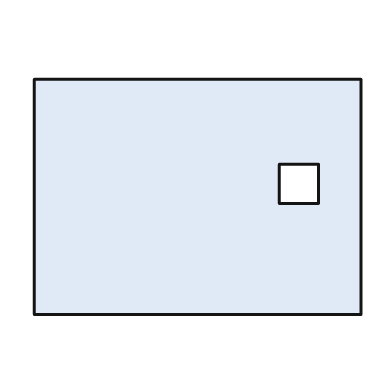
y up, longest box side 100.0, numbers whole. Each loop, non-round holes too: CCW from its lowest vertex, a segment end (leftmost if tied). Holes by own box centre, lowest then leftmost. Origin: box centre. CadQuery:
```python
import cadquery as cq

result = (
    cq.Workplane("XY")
    .moveTo(-50.0, -36.0)
    .lineTo(50.0, -36.0)
    .lineTo(50.0, 36.0)
    .lineTo(-50.0, 36.0)
    .close()
    .moveTo(25.0, -2.0)
    .lineTo(37.0, -2.0)
    .lineTo(37.0, 10.0)
    .lineTo(25.0, 10.0)
    .close()
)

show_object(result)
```